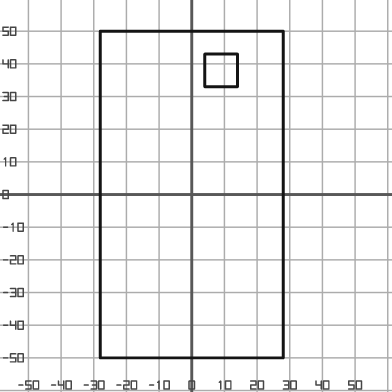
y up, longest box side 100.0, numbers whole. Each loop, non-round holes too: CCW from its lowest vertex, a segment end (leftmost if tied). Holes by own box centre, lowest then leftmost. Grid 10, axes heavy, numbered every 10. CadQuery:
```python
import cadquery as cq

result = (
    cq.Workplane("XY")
    .moveTo(-28.0, -50.0)
    .lineTo(28.0, -50.0)
    .lineTo(28.0, 50.0)
    .lineTo(-28.0, 50.0)
    .close()
    .moveTo(4.0, 33.0)
    .lineTo(14.0, 33.0)
    .lineTo(14.0, 43.0)
    .lineTo(4.0, 43.0)
    .close()
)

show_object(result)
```